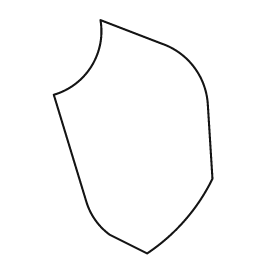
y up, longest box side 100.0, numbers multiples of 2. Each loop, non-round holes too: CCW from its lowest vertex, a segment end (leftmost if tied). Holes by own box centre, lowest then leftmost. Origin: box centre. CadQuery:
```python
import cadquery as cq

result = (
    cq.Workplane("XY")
    .moveTo(6.0, -50.0)
    .threePointArc((22.0, -36.0), (34.0, -18.0))
    .lineTo(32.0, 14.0)
    .threePointArc((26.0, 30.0), (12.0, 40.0))
    .lineTo(-14.0, 50.0)
    .threePointArc((-18.0, 30.0), (-34.0, 18.0))
    .lineTo(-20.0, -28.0)
    .threePointArc((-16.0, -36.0), (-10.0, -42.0))
    .close()
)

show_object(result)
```